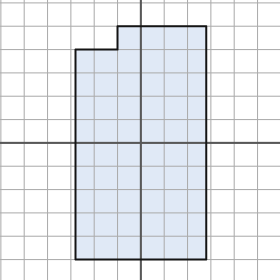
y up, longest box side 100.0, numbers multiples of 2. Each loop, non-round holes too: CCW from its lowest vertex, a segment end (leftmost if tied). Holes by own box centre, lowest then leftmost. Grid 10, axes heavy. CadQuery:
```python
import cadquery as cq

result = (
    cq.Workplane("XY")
    .moveTo(-28.0, -50.0)
    .lineTo(28.0, -50.0)
    .lineTo(28.0, 50.0)
    .lineTo(-10.0, 50.0)
    .lineTo(-10.0, 40.0)
    .lineTo(-28.0, 40.0)
    .close()
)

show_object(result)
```